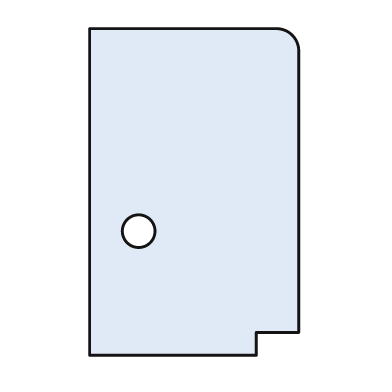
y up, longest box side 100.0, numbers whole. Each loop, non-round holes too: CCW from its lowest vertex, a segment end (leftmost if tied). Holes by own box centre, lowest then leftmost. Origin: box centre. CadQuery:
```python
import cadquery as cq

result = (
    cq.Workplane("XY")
    .moveTo(-32.0, -50.0)
    .lineTo(19.0, -50.0)
    .lineTo(19.0, -43.0)
    .lineTo(32.0, -43.0)
    .lineTo(32.0, 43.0)
    .threePointArc((30.0, 48.0), (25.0, 50.0))
    .lineTo(-32.0, 50.0)
    .close()
    .moveTo(-17.0, -12.0)
    .circle(5.0)
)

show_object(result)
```